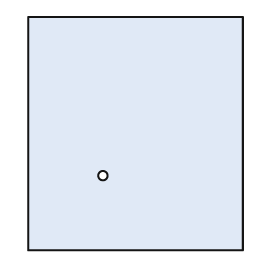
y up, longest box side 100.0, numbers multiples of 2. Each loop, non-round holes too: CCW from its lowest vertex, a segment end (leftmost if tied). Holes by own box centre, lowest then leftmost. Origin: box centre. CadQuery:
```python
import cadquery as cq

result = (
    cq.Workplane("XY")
    .moveTo(-46.0, -50.0)
    .lineTo(46.0, -50.0)
    .lineTo(46.0, 50.0)
    .lineTo(-46.0, 50.0)
    .close()
    .moveTo(-14.0, -18.0)
    .circle(2.0)
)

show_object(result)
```